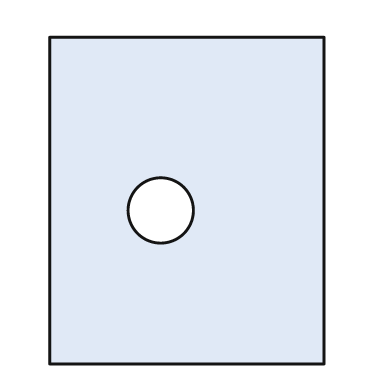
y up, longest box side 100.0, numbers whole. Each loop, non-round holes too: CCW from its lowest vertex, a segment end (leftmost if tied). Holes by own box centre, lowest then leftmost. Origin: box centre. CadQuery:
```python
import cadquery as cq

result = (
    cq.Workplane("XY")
    .moveTo(-42.0, -50.0)
    .lineTo(42.0, -50.0)
    .lineTo(42.0, 50.0)
    .lineTo(-42.0, 50.0)
    .close()
    .moveTo(-8.0, -3.0)
    .circle(10.0)
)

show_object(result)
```